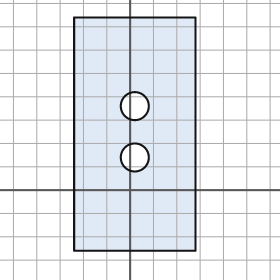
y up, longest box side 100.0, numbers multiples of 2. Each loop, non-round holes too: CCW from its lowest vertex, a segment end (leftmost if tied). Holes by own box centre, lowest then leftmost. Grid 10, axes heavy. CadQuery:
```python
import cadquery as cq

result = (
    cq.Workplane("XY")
    .moveTo(-24.0, -26.0)
    .lineTo(28.0, -26.0)
    .lineTo(28.0, 74.0)
    .lineTo(-24.0, 74.0)
    .close()
    .moveTo(2.0, 14.0)
    .circle(6.0)
    .moveTo(2.0, 36.0)
    .circle(6.0)
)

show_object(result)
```